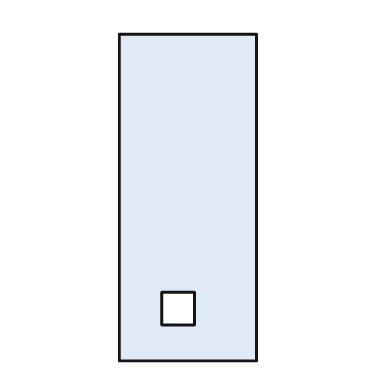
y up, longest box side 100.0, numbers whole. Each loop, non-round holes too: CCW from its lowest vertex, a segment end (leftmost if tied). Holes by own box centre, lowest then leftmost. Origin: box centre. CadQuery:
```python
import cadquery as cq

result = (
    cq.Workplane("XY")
    .moveTo(-21.0, -50.0)
    .lineTo(21.0, -50.0)
    .lineTo(21.0, 50.0)
    .lineTo(-21.0, 50.0)
    .close()
    .moveTo(-8.0, -39.0)
    .lineTo(2.0, -39.0)
    .lineTo(2.0, -29.0)
    .lineTo(-8.0, -29.0)
    .close()
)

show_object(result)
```